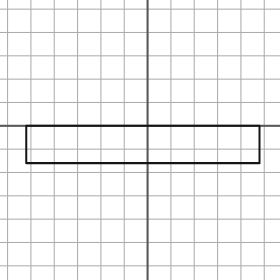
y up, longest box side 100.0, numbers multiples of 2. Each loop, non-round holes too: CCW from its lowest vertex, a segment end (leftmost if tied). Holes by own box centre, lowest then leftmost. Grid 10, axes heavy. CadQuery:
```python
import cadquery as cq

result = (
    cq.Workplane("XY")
    .moveTo(-52.0, -16.0)
    .lineTo(48.0, -16.0)
    .lineTo(48.0, 0.0)
    .lineTo(-52.0, 0.0)
    .close()
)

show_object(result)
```